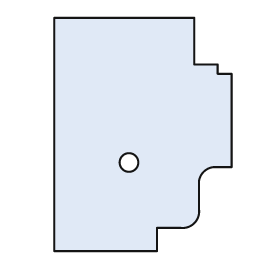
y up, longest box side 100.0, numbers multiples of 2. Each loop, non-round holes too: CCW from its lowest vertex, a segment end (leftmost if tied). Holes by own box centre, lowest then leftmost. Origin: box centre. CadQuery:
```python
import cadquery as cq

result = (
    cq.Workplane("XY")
    .moveTo(-38.0, -50.0)
    .lineTo(6.0, -50.0)
    .lineTo(6.0, -40.0)
    .lineTo(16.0, -40.0)
    .threePointArc((22.0, -38.0), (24.0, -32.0))
    .lineTo(24.0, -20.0)
    .threePointArc((26.0, -16.0), (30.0, -14.0))
    .lineTo(38.0, -14.0)
    .lineTo(38.0, 26.0)
    .lineTo(32.0, 26.0)
    .lineTo(32.0, 30.0)
    .lineTo(22.0, 30.0)
    .lineTo(22.0, 50.0)
    .lineTo(-38.0, 50.0)
    .close()
    .moveTo(-6.0, -12.0)
    .circle(4.0)
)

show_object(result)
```